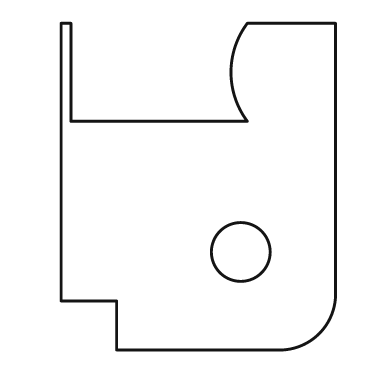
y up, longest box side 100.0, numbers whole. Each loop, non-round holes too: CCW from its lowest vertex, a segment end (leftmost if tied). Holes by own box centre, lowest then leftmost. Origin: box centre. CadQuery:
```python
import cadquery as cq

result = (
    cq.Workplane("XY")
    .moveTo(-25.0, -50.0)
    .lineTo(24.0, -50.0)
    .threePointArc((37.0, -45.0), (42.0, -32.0))
    .lineTo(42.0, 50.0)
    .lineTo(15.0, 50.0)
    .threePointArc((10.0, 35.0), (15.0, 20.0))
    .lineTo(-39.0, 20.0)
    .lineTo(-39.0, 50.0)
    .lineTo(-42.0, 50.0)
    .lineTo(-42.0, -35.0)
    .lineTo(-25.0, -35.0)
    .close()
    .moveTo(13.0, -20.0)
    .circle(9.0)
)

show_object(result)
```